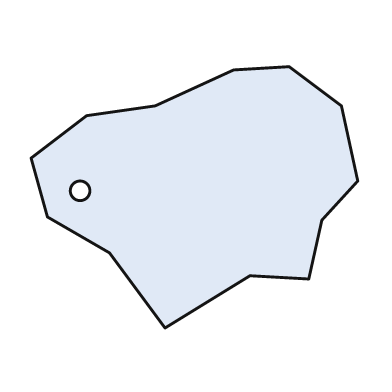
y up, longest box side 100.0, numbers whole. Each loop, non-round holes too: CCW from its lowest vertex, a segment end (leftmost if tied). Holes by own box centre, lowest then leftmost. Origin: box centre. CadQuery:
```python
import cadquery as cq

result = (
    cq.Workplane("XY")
    .moveTo(-9.0, -40.0)
    .lineTo(17.0, -24.0)
    .lineTo(35.0, -25.0)
    .lineTo(39.0, -7.0)
    .lineTo(50.0, 5.0)
    .lineTo(45.0, 28.0)
    .lineTo(29.0, 40.0)
    .lineTo(12.0, 39.0)
    .lineTo(-12.0, 28.0)
    .lineTo(-33.0, 25.0)
    .lineTo(-50.0, 12.0)
    .lineTo(-45.0, -6.0)
    .lineTo(-26.0, -17.0)
    .close()
    .moveTo(-35.0, 2.0)
    .circle(3.0)
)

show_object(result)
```